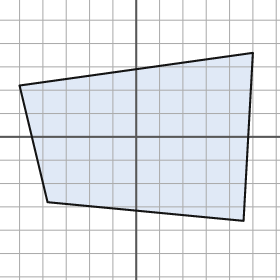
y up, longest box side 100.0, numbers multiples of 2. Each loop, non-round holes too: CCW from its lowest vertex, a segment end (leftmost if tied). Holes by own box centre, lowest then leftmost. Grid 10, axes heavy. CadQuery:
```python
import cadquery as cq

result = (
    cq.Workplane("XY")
    .moveTo(46.0, -36.0)
    .lineTo(50.0, 36.0)
    .lineTo(-50.0, 22.0)
    .lineTo(-38.0, -28.0)
    .close()
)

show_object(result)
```